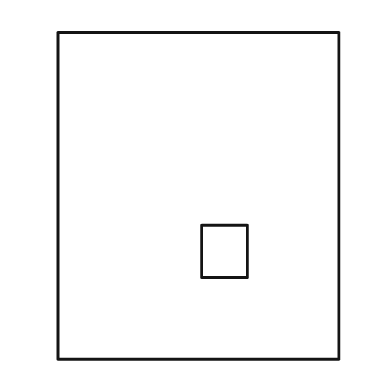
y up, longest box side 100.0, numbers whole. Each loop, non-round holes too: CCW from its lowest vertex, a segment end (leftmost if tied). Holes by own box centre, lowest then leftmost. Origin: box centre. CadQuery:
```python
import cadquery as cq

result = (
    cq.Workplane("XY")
    .moveTo(-43.0, -50.0)
    .lineTo(43.0, -50.0)
    .lineTo(43.0, 50.0)
    .lineTo(-43.0, 50.0)
    .close()
    .moveTo(1.0, -25.0)
    .lineTo(15.0, -25.0)
    .lineTo(15.0, -9.0)
    .lineTo(1.0, -9.0)
    .close()
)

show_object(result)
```